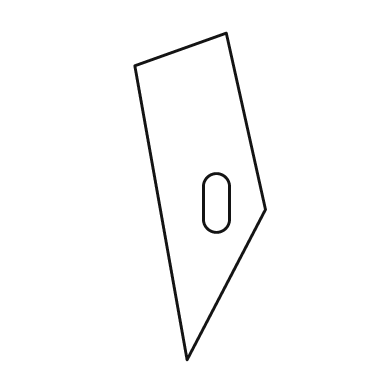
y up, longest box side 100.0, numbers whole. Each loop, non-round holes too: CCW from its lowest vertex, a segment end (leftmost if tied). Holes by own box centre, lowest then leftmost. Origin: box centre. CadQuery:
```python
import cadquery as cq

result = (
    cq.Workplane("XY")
    .moveTo(-4.0, -50.0)
    .lineTo(20.0, -4.0)
    .lineTo(8.0, 50.0)
    .lineTo(-20.0, 40.0)
    .close()
    .moveTo(1.0, -7.0)
    .threePointArc((5.0, -11.0), (9.0, -7.0))
    .lineTo(9.0, 3.0)
    .threePointArc((5.0, 7.0), (1.0, 3.0))
    .close()
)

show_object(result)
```